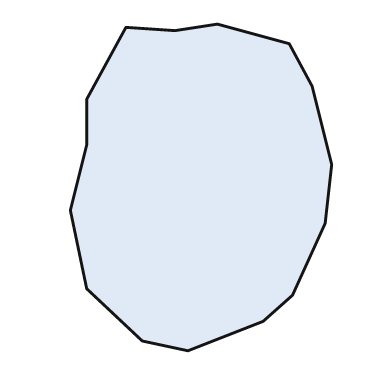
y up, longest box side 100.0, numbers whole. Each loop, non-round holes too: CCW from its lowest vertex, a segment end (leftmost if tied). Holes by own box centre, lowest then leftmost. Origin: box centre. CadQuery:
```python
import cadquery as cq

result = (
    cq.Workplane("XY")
    .moveTo(-4.0, -50.0)
    .lineTo(19.0, -41.0)
    .lineTo(28.0, -33.0)
    .lineTo(38.0, -11.0)
    .lineTo(40.0, 7.0)
    .lineTo(34.0, 31.0)
    .lineTo(27.0, 44.0)
    .lineTo(5.0, 50.0)
    .lineTo(-8.0, 48.0)
    .lineTo(-23.0, 49.0)
    .lineTo(-35.0, 27.0)
    .lineTo(-35.0, 13.0)
    .lineTo(-40.0, -7.0)
    .lineTo(-35.0, -31.0)
    .lineTo(-18.0, -47.0)
    .close()
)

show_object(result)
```